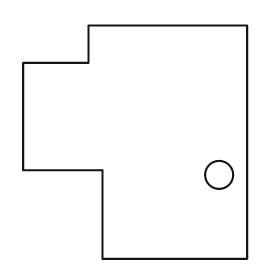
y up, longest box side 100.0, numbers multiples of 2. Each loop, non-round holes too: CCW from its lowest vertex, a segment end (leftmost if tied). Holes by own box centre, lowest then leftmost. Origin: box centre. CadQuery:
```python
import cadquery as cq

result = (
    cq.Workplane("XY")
    .moveTo(-14.0, -50.0)
    .lineTo(48.0, -50.0)
    .lineTo(48.0, 50.0)
    .lineTo(-20.0, 50.0)
    .lineTo(-20.0, 34.0)
    .lineTo(-48.0, 34.0)
    .lineTo(-48.0, -12.0)
    .lineTo(-14.0, -12.0)
    .close()
    .moveTo(36.0, -14.0)
    .circle(6.0)
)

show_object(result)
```